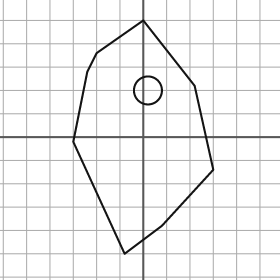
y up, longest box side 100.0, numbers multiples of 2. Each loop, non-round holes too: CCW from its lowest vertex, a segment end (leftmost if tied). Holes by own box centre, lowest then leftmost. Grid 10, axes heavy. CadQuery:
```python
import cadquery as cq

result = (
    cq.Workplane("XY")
    .moveTo(-8.0, -50.0)
    .lineTo(8.0, -38.0)
    .lineTo(30.0, -14.0)
    .lineTo(22.0, 22.0)
    .lineTo(0.0, 50.0)
    .lineTo(-20.0, 36.0)
    .lineTo(-24.0, 28.0)
    .lineTo(-30.0, -2.0)
    .close()
    .moveTo(2.0, 20.0)
    .circle(6.0)
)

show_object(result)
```